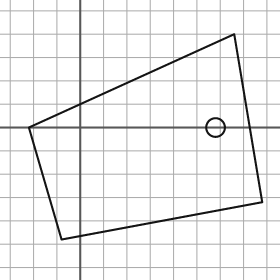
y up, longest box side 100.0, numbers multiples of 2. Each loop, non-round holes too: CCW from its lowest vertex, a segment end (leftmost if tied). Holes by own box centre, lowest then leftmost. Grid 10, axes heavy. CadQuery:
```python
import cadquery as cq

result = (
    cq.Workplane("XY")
    .moveTo(-8.0, -48.0)
    .lineTo(78.0, -32.0)
    .lineTo(66.0, 40.0)
    .lineTo(-22.0, 0.0)
    .close()
    .moveTo(58.0, 0.0)
    .circle(4.0)
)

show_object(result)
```